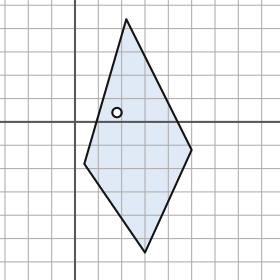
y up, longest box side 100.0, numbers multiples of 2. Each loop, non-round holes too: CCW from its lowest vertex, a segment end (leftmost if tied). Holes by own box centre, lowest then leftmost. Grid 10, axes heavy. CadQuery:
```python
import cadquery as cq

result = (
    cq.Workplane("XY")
    .moveTo(30.0, -56.0)
    .lineTo(50.0, -12.0)
    .lineTo(22.0, 44.0)
    .lineTo(4.0, -18.0)
    .close()
    .moveTo(18.0, 4.0)
    .circle(2.0)
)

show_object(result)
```